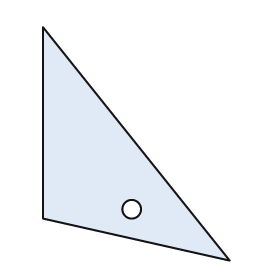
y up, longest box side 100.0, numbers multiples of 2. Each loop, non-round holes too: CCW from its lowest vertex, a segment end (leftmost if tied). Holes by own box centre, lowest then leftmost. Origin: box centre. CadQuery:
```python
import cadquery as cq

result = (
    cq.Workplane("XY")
    .moveTo(40.0, -50.0)
    .lineTo(-40.0, 50.0)
    .lineTo(-40.0, -32.0)
    .close()
    .moveTo(-2.0, -28.0)
    .circle(4.0)
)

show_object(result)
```